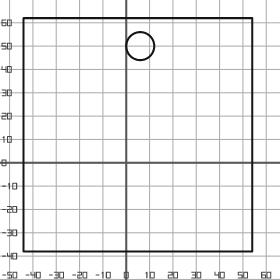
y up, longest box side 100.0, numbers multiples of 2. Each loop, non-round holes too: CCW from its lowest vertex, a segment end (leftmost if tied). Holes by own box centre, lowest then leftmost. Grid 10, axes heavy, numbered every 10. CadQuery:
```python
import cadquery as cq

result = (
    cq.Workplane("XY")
    .moveTo(-44.0, -38.0)
    .lineTo(54.0, -38.0)
    .lineTo(54.0, 62.0)
    .lineTo(-44.0, 62.0)
    .close()
    .moveTo(6.0, 50.0)
    .circle(6.0)
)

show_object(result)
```